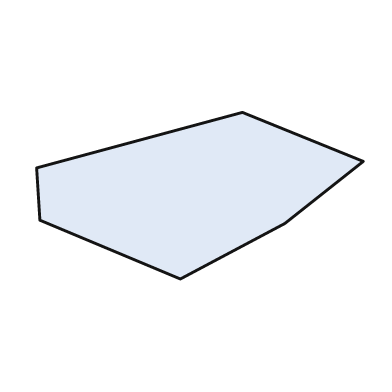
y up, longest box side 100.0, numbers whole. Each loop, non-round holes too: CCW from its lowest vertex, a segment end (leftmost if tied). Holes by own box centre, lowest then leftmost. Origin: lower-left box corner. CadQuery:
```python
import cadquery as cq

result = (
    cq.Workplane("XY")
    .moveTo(44.0, 0.0)
    .lineTo(76.0, 17.0)
    .lineTo(100.0, 36.0)
    .lineTo(63.0, 51.0)
    .lineTo(0.0, 34.0)
    .lineTo(1.0, 18.0)
    .close()
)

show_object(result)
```